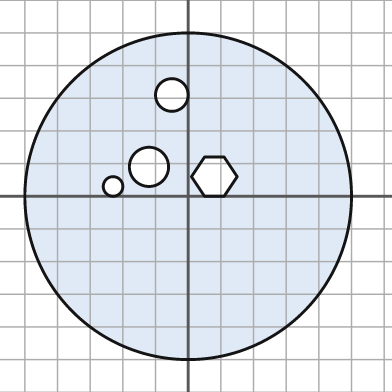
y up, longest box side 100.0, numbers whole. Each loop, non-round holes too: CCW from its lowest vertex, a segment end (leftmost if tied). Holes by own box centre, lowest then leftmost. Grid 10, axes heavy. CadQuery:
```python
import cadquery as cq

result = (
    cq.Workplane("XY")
    .moveTo(0.0, 0.0)
    .circle(50.0)
    .moveTo(-23.0, 3.0)
    .circle(3.0)
    .moveTo(5.0, 0.0)
    .lineTo(11.0, 0.0)
    .lineTo(15.0, 6.0)
    .lineTo(11.0, 12.0)
    .lineTo(5.0, 12.0)
    .lineTo(1.0, 6.0)
    .close()
    .moveTo(-12.0, 9.0)
    .circle(6.0)
    .moveTo(-5.0, 31.0)
    .circle(5.0)
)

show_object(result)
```